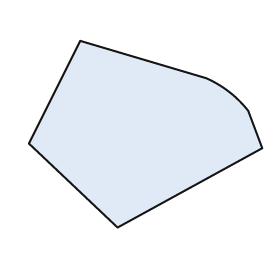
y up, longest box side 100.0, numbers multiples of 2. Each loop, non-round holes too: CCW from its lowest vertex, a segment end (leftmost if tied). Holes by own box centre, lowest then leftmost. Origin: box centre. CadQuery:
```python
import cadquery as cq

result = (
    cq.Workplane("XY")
    .moveTo(-12.0, -40.0)
    .lineTo(50.0, -6.0)
    .lineTo(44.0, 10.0)
    .threePointArc((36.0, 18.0), (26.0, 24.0))
    .lineTo(-28.0, 40.0)
    .lineTo(-50.0, -4.0)
    .close()
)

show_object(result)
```